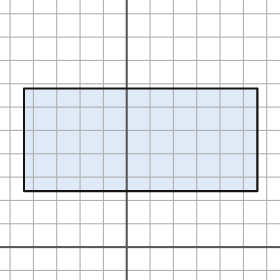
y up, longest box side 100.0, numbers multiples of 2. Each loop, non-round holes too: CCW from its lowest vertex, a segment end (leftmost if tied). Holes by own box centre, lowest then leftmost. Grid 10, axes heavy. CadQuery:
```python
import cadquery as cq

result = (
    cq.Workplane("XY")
    .moveTo(-44.0, 24.0)
    .lineTo(56.0, 24.0)
    .lineTo(56.0, 68.0)
    .lineTo(-44.0, 68.0)
    .close()
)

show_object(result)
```